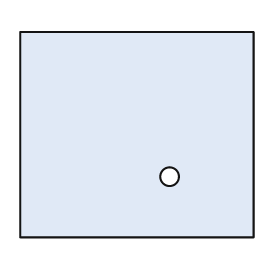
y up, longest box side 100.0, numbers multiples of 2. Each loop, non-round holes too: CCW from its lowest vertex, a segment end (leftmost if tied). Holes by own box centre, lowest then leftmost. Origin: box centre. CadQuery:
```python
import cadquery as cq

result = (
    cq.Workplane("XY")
    .moveTo(-50.0, -44.0)
    .lineTo(50.0, -44.0)
    .lineTo(50.0, 44.0)
    .lineTo(-50.0, 44.0)
    .close()
    .moveTo(14.0, -18.0)
    .circle(4.0)
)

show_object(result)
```